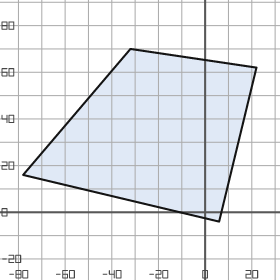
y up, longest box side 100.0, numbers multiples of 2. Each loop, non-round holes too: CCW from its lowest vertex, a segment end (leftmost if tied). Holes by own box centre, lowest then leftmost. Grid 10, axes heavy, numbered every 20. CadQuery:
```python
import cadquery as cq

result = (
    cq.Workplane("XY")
    .moveTo(6.0, -4.0)
    .lineTo(22.0, 62.0)
    .lineTo(-32.0, 70.0)
    .lineTo(-78.0, 16.0)
    .close()
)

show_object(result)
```